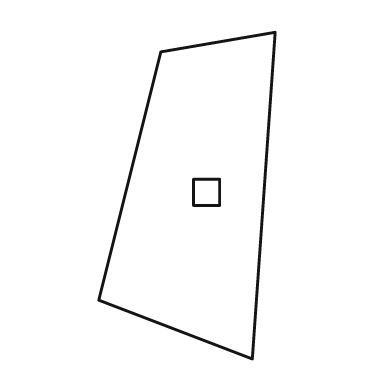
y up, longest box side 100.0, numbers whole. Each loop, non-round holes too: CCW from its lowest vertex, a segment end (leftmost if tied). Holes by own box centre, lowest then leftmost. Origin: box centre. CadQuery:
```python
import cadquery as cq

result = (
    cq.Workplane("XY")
    .moveTo(20.0, -50.0)
    .lineTo(27.0, 50.0)
    .lineTo(-8.0, 44.0)
    .lineTo(-27.0, -32.0)
    .close()
    .moveTo(2.0, -3.0)
    .lineTo(10.0, -3.0)
    .lineTo(10.0, 5.0)
    .lineTo(2.0, 5.0)
    .close()
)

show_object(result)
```